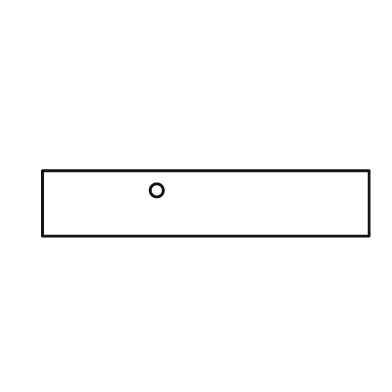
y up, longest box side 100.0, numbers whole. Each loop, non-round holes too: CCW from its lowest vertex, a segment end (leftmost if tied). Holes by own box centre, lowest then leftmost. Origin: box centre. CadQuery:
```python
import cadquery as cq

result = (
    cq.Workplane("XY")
    .moveTo(-50.0, -10.0)
    .lineTo(50.0, -10.0)
    .lineTo(50.0, 10.0)
    .lineTo(-50.0, 10.0)
    .close()
    .moveTo(-15.0, 4.0)
    .circle(2.0)
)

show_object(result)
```